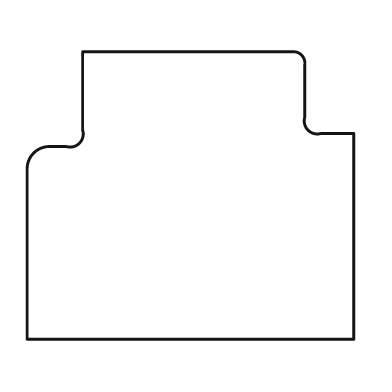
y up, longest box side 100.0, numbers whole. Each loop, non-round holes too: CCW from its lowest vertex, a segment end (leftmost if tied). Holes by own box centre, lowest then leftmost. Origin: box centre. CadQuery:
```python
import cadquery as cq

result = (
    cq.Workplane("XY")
    .moveTo(-50.0, -44.0)
    .lineTo(50.0, -44.0)
    .lineTo(50.0, 19.0)
    .lineTo(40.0, 19.0)
    .threePointArc((36.0, 20.0), (35.0, 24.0))
    .lineTo(35.0, 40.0)
    .threePointArc((34.0, 43.0), (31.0, 44.0))
    .lineTo(-33.0, 44.0)
    .lineTo(-33.0, 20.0)
    .threePointArc((-34.0, 16.0), (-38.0, 15.0))
    .lineTo(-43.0, 15.0)
    .threePointArc((-48.0, 13.0), (-50.0, 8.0))
    .close()
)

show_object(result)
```